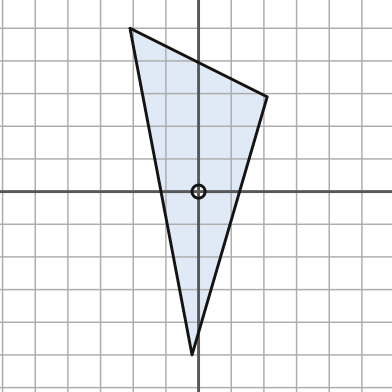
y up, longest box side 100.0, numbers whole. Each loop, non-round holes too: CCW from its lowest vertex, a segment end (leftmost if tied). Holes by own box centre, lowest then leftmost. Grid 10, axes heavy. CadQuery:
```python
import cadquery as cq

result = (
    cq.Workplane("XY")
    .moveTo(-2.0, -50.0)
    .lineTo(21.0, 29.0)
    .lineTo(-21.0, 50.0)
    .close()
    .moveTo(0.0, 0.0)
    .circle(2.0)
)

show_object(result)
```